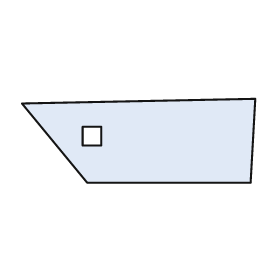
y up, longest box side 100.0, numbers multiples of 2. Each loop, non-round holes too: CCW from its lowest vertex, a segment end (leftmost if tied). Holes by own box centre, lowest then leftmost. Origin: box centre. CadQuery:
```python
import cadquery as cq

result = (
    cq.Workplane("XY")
    .moveTo(-22.0, -18.0)
    .lineTo(48.0, -18.0)
    .lineTo(50.0, 18.0)
    .lineTo(-50.0, 16.0)
    .close()
    .moveTo(-24.0, -2.0)
    .lineTo(-16.0, -2.0)
    .lineTo(-16.0, 6.0)
    .lineTo(-24.0, 6.0)
    .close()
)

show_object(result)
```